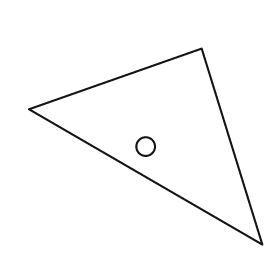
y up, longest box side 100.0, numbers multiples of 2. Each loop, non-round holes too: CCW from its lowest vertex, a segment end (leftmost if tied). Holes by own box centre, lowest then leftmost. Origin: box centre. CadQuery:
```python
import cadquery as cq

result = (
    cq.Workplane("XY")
    .moveTo(50.0, -42.0)
    .lineTo(24.0, 42.0)
    .lineTo(-50.0, 16.0)
    .close()
    .moveTo(0.0, 0.0)
    .circle(4.0)
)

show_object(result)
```